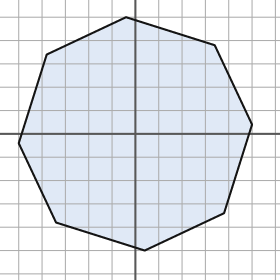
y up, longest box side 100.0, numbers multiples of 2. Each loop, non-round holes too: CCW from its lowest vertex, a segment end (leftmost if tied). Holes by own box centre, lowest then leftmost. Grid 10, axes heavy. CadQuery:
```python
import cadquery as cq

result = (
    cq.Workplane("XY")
    .moveTo(4.0, -50.0)
    .lineTo(38.0, -34.0)
    .lineTo(50.0, 4.0)
    .lineTo(34.0, 38.0)
    .lineTo(-4.0, 50.0)
    .lineTo(-38.0, 34.0)
    .lineTo(-50.0, -4.0)
    .lineTo(-34.0, -38.0)
    .close()
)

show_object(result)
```